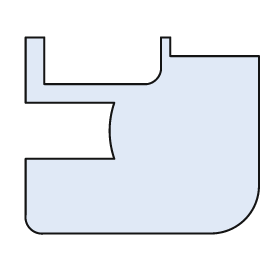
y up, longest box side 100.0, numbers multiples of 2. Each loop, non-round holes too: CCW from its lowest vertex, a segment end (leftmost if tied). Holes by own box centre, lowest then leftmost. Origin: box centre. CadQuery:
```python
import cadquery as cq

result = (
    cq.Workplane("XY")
    .moveTo(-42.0, -42.0)
    .lineTo(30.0, -42.0)
    .threePointArc((44.0, -36.0), (50.0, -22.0))
    .lineTo(50.0, 34.0)
    .lineTo(12.0, 34.0)
    .lineTo(12.0, 42.0)
    .lineTo(8.0, 42.0)
    .lineTo(8.0, 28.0)
    .threePointArc((6.0, 24.0), (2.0, 22.0))
    .lineTo(-42.0, 22.0)
    .lineTo(-42.0, 42.0)
    .lineTo(-50.0, 42.0)
    .lineTo(-50.0, 14.0)
    .lineTo(-12.0, 14.0)
    .threePointArc((-14.0, 2.0), (-12.0, -10.0))
    .lineTo(-50.0, -10.0)
    .lineTo(-50.0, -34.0)
    .threePointArc((-48.0, -40.0), (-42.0, -42.0))
    .close()
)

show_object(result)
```